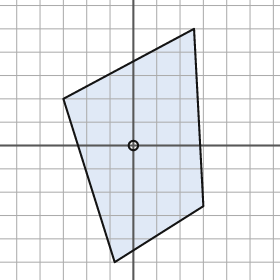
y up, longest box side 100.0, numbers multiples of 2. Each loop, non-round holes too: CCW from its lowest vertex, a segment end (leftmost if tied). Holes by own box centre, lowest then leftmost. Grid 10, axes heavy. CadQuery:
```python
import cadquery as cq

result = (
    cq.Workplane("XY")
    .moveTo(-8.0, -50.0)
    .lineTo(30.0, -26.0)
    .lineTo(26.0, 50.0)
    .lineTo(-30.0, 20.0)
    .close()
    .moveTo(0.0, 0.0)
    .circle(2.0)
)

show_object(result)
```